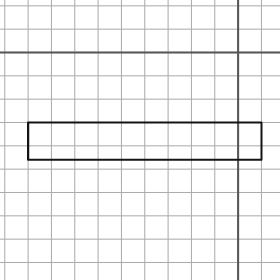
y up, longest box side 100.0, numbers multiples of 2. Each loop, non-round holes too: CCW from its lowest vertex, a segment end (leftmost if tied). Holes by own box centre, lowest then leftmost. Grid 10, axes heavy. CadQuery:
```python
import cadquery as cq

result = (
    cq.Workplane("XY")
    .moveTo(-90.0, -46.0)
    .lineTo(10.0, -46.0)
    .lineTo(10.0, -30.0)
    .lineTo(-90.0, -30.0)
    .close()
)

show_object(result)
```